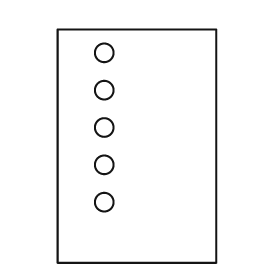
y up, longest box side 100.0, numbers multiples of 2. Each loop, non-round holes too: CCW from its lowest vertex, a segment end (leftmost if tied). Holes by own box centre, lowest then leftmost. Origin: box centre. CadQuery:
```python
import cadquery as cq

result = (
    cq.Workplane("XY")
    .moveTo(-34.0, -50.0)
    .lineTo(34.0, -50.0)
    .lineTo(34.0, 50.0)
    .lineTo(-34.0, 50.0)
    .close()
    .moveTo(-14.0, -24.0)
    .circle(4.0)
    .moveTo(-14.0, -8.0)
    .circle(4.0)
    .moveTo(-14.0, 8.0)
    .circle(4.0)
    .moveTo(-14.0, 24.0)
    .circle(4.0)
    .moveTo(-14.0, 40.0)
    .circle(4.0)
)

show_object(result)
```